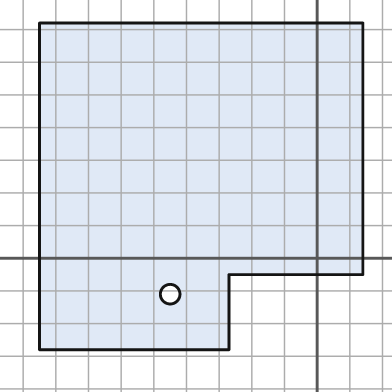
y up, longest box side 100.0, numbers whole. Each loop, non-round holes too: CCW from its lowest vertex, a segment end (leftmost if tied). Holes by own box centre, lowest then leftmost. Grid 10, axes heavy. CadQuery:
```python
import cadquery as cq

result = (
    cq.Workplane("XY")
    .moveTo(-85.0, -28.0)
    .lineTo(-27.0, -28.0)
    .lineTo(-27.0, -5.0)
    .lineTo(14.0, -5.0)
    .lineTo(14.0, 72.0)
    .lineTo(-85.0, 72.0)
    .close()
    .moveTo(-45.0, -11.0)
    .circle(3.0)
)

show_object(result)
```